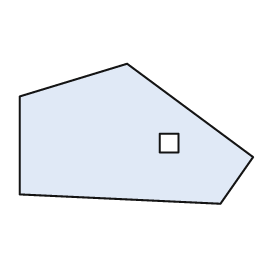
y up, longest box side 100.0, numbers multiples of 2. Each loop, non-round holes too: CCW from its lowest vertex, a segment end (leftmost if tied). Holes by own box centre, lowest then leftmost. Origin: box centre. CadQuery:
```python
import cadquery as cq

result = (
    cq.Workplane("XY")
    .moveTo(36.0, -30.0)
    .lineTo(50.0, -10.0)
    .lineTo(-4.0, 30.0)
    .lineTo(-50.0, 16.0)
    .lineTo(-50.0, -26.0)
    .close()
    .moveTo(10.0, -8.0)
    .lineTo(18.0, -8.0)
    .lineTo(18.0, 0.0)
    .lineTo(10.0, 0.0)
    .close()
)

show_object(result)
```